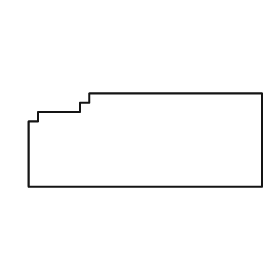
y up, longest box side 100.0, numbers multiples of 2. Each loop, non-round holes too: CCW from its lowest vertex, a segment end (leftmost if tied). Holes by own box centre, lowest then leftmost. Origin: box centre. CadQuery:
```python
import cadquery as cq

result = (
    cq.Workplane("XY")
    .moveTo(-50.0, -20.0)
    .lineTo(50.0, -20.0)
    .lineTo(50.0, 20.0)
    .lineTo(-24.0, 20.0)
    .lineTo(-24.0, 16.0)
    .lineTo(-28.0, 16.0)
    .lineTo(-28.0, 12.0)
    .lineTo(-46.0, 12.0)
    .lineTo(-46.0, 8.0)
    .lineTo(-50.0, 8.0)
    .close()
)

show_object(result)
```